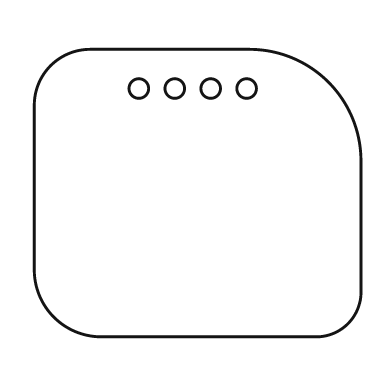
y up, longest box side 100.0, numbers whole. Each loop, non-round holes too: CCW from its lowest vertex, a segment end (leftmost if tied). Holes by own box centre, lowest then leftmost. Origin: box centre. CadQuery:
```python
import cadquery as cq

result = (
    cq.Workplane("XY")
    .moveTo(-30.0, -44.0)
    .lineTo(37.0, -44.0)
    .threePointArc((46.0, -40.0), (50.0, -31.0))
    .lineTo(50.0, 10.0)
    .threePointArc((40.0, 34.0), (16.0, 44.0))
    .lineTo(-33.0, 44.0)
    .threePointArc((-45.0, 39.0), (-50.0, 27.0))
    .lineTo(-50.0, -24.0)
    .threePointArc((-44.0, -38.0), (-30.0, -44.0))
    .close()
    .moveTo(-18.0, 32.0)
    .circle(3.0)
    .moveTo(-7.0, 32.0)
    .circle(3.0)
    .moveTo(4.0, 32.0)
    .circle(3.0)
    .moveTo(15.0, 32.0)
    .circle(3.0)
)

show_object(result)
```